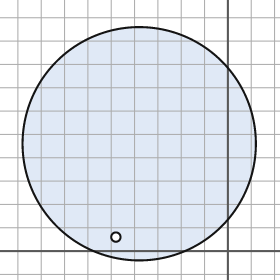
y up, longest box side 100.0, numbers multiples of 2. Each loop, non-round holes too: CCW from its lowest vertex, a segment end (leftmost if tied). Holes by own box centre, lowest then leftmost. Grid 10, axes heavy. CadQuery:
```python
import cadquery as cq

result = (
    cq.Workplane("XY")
    .moveTo(-38.0, 46.0)
    .circle(50.0)
    .moveTo(-48.0, 6.0)
    .circle(2.0)
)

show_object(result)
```